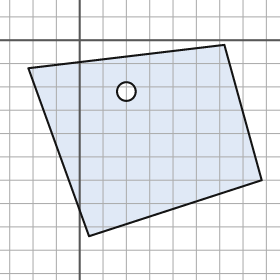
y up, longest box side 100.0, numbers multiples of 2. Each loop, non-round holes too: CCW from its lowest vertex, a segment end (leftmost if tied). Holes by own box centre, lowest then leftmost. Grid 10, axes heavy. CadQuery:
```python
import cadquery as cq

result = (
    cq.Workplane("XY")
    .moveTo(4.0, -84.0)
    .lineTo(78.0, -60.0)
    .lineTo(62.0, -2.0)
    .lineTo(-22.0, -12.0)
    .close()
    .moveTo(20.0, -22.0)
    .circle(4.0)
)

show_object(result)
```